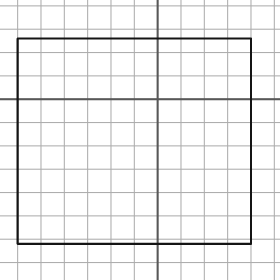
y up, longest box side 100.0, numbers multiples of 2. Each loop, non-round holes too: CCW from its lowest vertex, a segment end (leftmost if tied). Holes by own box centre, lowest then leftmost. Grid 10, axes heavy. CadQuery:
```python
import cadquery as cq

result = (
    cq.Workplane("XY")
    .moveTo(-60.0, -62.0)
    .lineTo(40.0, -62.0)
    .lineTo(40.0, 26.0)
    .lineTo(-60.0, 26.0)
    .close()
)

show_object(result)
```